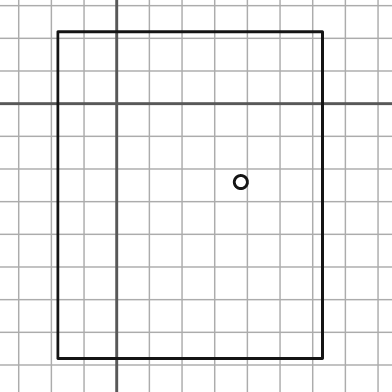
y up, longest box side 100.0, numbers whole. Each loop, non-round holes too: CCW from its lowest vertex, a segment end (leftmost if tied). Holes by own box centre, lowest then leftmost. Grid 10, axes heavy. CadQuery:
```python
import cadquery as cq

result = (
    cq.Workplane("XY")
    .moveTo(-18.0, -78.0)
    .lineTo(63.0, -78.0)
    .lineTo(63.0, 22.0)
    .lineTo(-18.0, 22.0)
    .close()
    .moveTo(38.0, -24.0)
    .circle(2.0)
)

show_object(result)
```